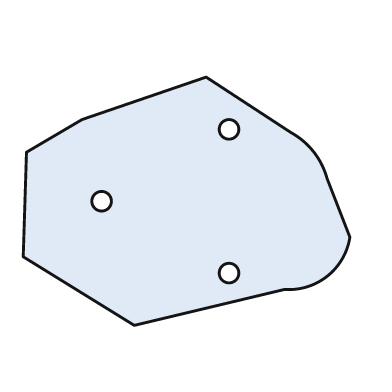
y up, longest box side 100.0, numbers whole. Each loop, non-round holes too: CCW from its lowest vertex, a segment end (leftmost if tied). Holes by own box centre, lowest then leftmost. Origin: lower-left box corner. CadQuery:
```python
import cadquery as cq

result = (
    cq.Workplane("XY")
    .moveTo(34.0, 0.0)
    .lineTo(80.0, 11.0)
    .threePointArc((93.0, 15.0), (100.0, 27.0))
    .lineTo(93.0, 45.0)
    .threePointArc((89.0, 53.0), (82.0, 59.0))
    .lineTo(56.0, 76.0)
    .lineTo(18.0, 63.0)
    .lineTo(1.0, 53.0)
    .lineTo(0.0, 21.0)
    .close()
    .moveTo(63.0, 16.0)
    .circle(3.0)
    .moveTo(24.0, 38.0)
    .circle(3.0)
    .moveTo(63.0, 60.0)
    .circle(3.0)
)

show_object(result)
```